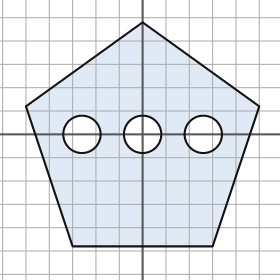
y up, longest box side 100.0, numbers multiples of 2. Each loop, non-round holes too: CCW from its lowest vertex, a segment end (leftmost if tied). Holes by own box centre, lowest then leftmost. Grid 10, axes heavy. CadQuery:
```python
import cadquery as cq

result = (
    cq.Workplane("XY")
    .moveTo(-30.0, -48.0)
    .lineTo(30.0, -48.0)
    .lineTo(50.0, 12.0)
    .lineTo(0.0, 48.0)
    .lineTo(-50.0, 12.0)
    .close()
    .moveTo(-26.0, 0.0)
    .circle(8.0)
    .moveTo(0.0, 0.0)
    .circle(8.0)
    .moveTo(26.0, 0.0)
    .circle(8.0)
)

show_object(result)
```